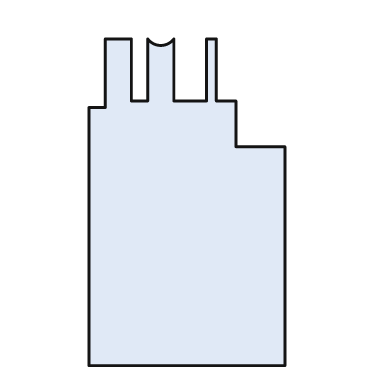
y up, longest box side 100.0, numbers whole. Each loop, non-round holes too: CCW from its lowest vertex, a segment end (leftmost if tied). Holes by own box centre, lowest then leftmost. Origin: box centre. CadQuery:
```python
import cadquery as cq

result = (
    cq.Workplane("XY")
    .moveTo(-30.0, -50.0)
    .lineTo(30.0, -50.0)
    .lineTo(30.0, 17.0)
    .lineTo(15.0, 17.0)
    .lineTo(15.0, 31.0)
    .lineTo(9.0, 31.0)
    .lineTo(9.0, 50.0)
    .lineTo(6.0, 50.0)
    .lineTo(6.0, 31.0)
    .lineTo(-4.0, 31.0)
    .lineTo(-4.0, 50.0)
    .threePointArc((-8.0, 48.0), (-12.0, 50.0))
    .lineTo(-12.0, 31.0)
    .lineTo(-17.0, 31.0)
    .lineTo(-17.0, 50.0)
    .lineTo(-25.0, 50.0)
    .lineTo(-25.0, 29.0)
    .lineTo(-30.0, 29.0)
    .close()
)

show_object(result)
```